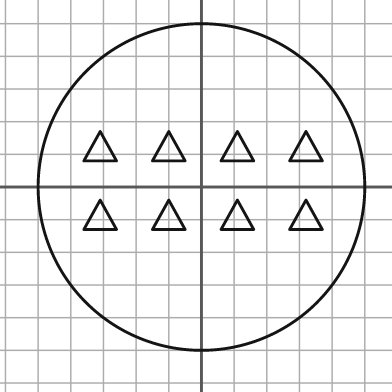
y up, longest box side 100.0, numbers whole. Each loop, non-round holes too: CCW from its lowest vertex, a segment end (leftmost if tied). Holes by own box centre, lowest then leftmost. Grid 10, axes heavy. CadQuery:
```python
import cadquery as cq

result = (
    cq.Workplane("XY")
    .moveTo(0.0, 0.0)
    .circle(50.0)
    .moveTo(-36.0, -13.0)
    .lineTo(-26.0, -13.0)
    .lineTo(-31.0, -4.0)
    .close()
    .moveTo(-15.0, -13.0)
    .lineTo(-5.0, -13.0)
    .lineTo(-10.0, -4.0)
    .close()
    .moveTo(6.0, -13.0)
    .lineTo(16.0, -13.0)
    .lineTo(11.0, -4.0)
    .close()
    .moveTo(27.0, -13.0)
    .lineTo(37.0, -13.0)
    .lineTo(32.0, -4.0)
    .close()
    .moveTo(-36.0, 8.0)
    .lineTo(-26.0, 8.0)
    .lineTo(-31.0, 17.0)
    .close()
    .moveTo(-15.0, 8.0)
    .lineTo(-5.0, 8.0)
    .lineTo(-10.0, 17.0)
    .close()
    .moveTo(6.0, 8.0)
    .lineTo(16.0, 8.0)
    .lineTo(11.0, 17.0)
    .close()
    .moveTo(27.0, 8.0)
    .lineTo(37.0, 8.0)
    .lineTo(32.0, 17.0)
    .close()
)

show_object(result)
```